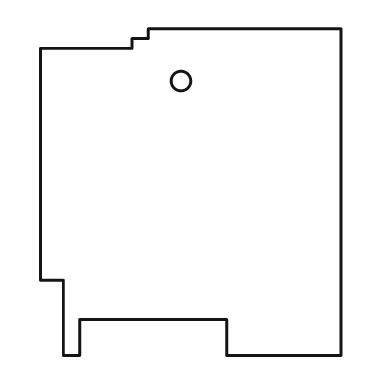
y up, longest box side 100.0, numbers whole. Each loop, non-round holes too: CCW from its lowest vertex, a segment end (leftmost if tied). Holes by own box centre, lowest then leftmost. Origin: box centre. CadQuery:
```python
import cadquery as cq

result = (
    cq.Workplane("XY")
    .moveTo(-39.0, -50.0)
    .lineTo(-34.0, -50.0)
    .lineTo(-34.0, -39.0)
    .lineTo(11.0, -39.0)
    .lineTo(11.0, -50.0)
    .lineTo(46.0, -50.0)
    .lineTo(46.0, 50.0)
    .lineTo(-13.0, 50.0)
    .lineTo(-13.0, 47.0)
    .lineTo(-18.0, 47.0)
    .lineTo(-18.0, 44.0)
    .lineTo(-46.0, 44.0)
    .lineTo(-46.0, -27.0)
    .lineTo(-39.0, -27.0)
    .close()
    .moveTo(-3.0, 34.0)
    .circle(3.0)
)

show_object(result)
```